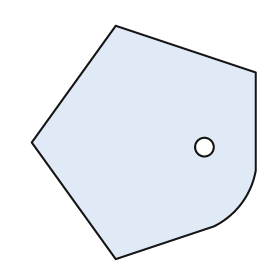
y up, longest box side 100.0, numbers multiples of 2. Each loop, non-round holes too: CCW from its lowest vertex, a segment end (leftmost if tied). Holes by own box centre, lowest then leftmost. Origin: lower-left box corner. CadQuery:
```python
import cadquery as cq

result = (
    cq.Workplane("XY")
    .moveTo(36.0, 0.0)
    .lineTo(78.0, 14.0)
    .threePointArc((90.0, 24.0), (96.0, 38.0))
    .lineTo(96.0, 80.0)
    .lineTo(36.0, 100.0)
    .lineTo(0.0, 50.0)
    .close()
    .moveTo(74.0, 48.0)
    .circle(4.0)
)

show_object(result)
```